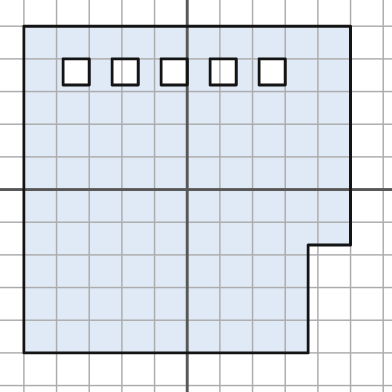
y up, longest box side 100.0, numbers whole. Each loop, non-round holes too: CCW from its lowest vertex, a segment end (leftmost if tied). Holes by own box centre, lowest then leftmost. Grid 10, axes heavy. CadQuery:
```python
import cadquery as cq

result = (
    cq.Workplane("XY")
    .moveTo(-50.0, -50.0)
    .lineTo(37.0, -50.0)
    .lineTo(37.0, -17.0)
    .lineTo(50.0, -17.0)
    .lineTo(50.0, 50.0)
    .lineTo(-50.0, 50.0)
    .close()
    .moveTo(-38.0, 32.0)
    .lineTo(-30.0, 32.0)
    .lineTo(-30.0, 40.0)
    .lineTo(-38.0, 40.0)
    .close()
    .moveTo(-23.0, 32.0)
    .lineTo(-15.0, 32.0)
    .lineTo(-15.0, 40.0)
    .lineTo(-23.0, 40.0)
    .close()
    .moveTo(-8.0, 32.0)
    .lineTo(0.0, 32.0)
    .lineTo(0.0, 40.0)
    .lineTo(-8.0, 40.0)
    .close()
    .moveTo(7.0, 32.0)
    .lineTo(15.0, 32.0)
    .lineTo(15.0, 40.0)
    .lineTo(7.0, 40.0)
    .close()
    .moveTo(22.0, 32.0)
    .lineTo(30.0, 32.0)
    .lineTo(30.0, 40.0)
    .lineTo(22.0, 40.0)
    .close()
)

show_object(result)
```